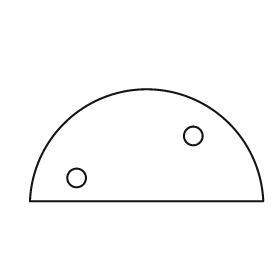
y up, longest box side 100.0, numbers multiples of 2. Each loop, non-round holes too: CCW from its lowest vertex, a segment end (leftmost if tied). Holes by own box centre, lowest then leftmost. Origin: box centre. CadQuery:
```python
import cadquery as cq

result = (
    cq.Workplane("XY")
    .moveTo(-50.0, -24.0)
    .lineTo(50.0, -24.0)
    .threePointArc((0.0, 24.0), (-50.0, -24.0))
    .close()
    .moveTo(-30.0, -14.0)
    .circle(4.0)
    .moveTo(20.0, 4.0)
    .circle(4.0)
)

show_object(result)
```